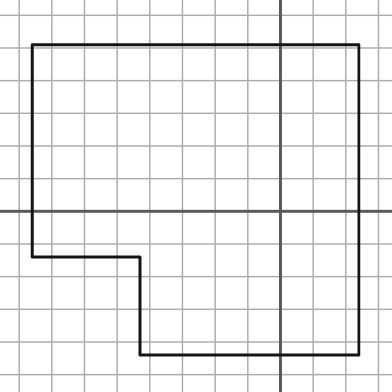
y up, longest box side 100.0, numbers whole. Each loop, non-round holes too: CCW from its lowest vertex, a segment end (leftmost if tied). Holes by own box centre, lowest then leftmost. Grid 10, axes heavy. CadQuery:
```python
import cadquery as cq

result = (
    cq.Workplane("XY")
    .moveTo(-43.0, -44.0)
    .lineTo(24.0, -44.0)
    .lineTo(24.0, 51.0)
    .lineTo(-76.0, 51.0)
    .lineTo(-76.0, -14.0)
    .lineTo(-43.0, -14.0)
    .close()
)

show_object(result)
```